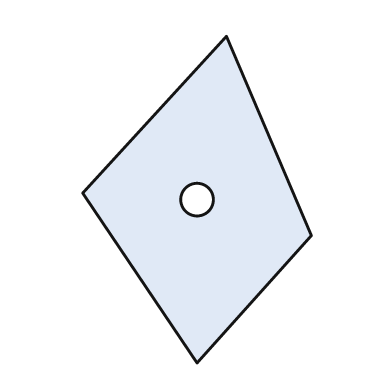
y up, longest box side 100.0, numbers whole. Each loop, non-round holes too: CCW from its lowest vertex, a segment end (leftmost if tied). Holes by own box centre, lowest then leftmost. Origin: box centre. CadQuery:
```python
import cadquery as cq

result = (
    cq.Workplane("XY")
    .moveTo(0.0, -50.0)
    .lineTo(35.0, -11.0)
    .lineTo(9.0, 50.0)
    .lineTo(-35.0, 2.0)
    .close()
    .moveTo(0.0, 0.0)
    .circle(5.0)
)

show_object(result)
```